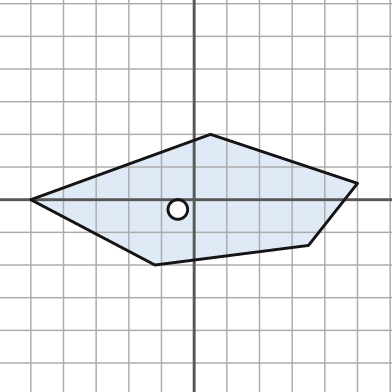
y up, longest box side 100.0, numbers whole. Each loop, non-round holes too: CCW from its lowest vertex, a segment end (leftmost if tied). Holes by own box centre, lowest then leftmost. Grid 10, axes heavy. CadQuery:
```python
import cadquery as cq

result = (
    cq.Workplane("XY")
    .moveTo(-12.0, -20.0)
    .lineTo(35.0, -14.0)
    .lineTo(50.0, 5.0)
    .lineTo(5.0, 20.0)
    .lineTo(-50.0, 0.0)
    .close()
    .moveTo(-5.0, -3.0)
    .circle(3.0)
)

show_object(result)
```